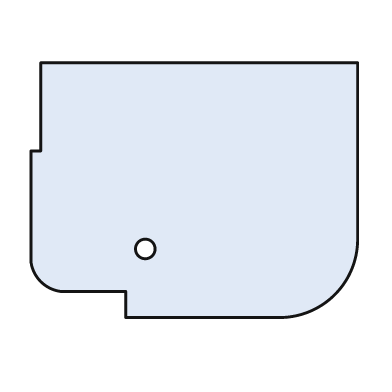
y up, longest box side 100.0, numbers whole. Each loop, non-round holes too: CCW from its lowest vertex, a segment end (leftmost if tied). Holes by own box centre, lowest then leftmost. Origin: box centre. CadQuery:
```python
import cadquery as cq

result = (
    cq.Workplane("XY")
    .moveTo(-21.0, -39.0)
    .lineTo(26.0, -39.0)
    .threePointArc((43.0, -32.0), (50.0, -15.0))
    .lineTo(50.0, 39.0)
    .lineTo(-47.0, 39.0)
    .lineTo(-47.0, 12.0)
    .lineTo(-50.0, 12.0)
    .lineTo(-50.0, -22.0)
    .threePointArc((-47.0, -28.0), (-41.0, -31.0))
    .lineTo(-21.0, -31.0)
    .close()
    .moveTo(-15.0, -18.0)
    .circle(3.0)
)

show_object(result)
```